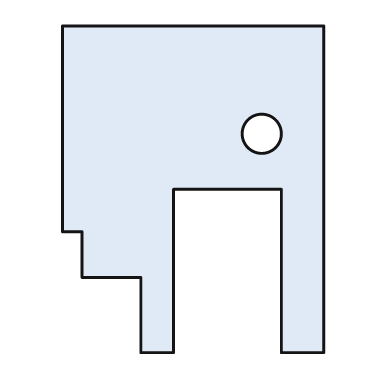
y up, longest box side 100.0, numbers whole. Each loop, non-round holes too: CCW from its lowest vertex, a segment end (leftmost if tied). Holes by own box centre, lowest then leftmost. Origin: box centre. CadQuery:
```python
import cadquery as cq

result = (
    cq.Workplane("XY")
    .moveTo(-16.0, -50.0)
    .lineTo(-6.0, -50.0)
    .lineTo(-6.0, 0.0)
    .lineTo(27.0, 0.0)
    .lineTo(27.0, -50.0)
    .lineTo(40.0, -50.0)
    .lineTo(40.0, 50.0)
    .lineTo(-40.0, 50.0)
    .lineTo(-40.0, -13.0)
    .lineTo(-34.0, -13.0)
    .lineTo(-34.0, -27.0)
    .lineTo(-16.0, -27.0)
    .close()
    .moveTo(21.0, 17.0)
    .circle(6.0)
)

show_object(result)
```